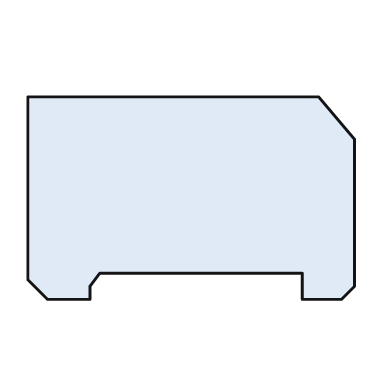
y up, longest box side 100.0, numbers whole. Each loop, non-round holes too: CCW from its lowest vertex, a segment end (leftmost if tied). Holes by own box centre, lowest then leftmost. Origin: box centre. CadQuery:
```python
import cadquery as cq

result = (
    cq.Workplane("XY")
    .moveTo(-44.0, -31.0)
    .lineTo(-31.0, -31.0)
    .lineTo(-31.0, -27.0)
    .lineTo(-28.0, -23.0)
    .lineTo(34.0, -23.0)
    .lineTo(34.0, -31.0)
    .lineTo(46.0, -31.0)
    .lineTo(50.0, -27.0)
    .lineTo(50.0, 18.0)
    .lineTo(39.0, 31.0)
    .lineTo(-50.0, 31.0)
    .lineTo(-50.0, -25.0)
    .close()
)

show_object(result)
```